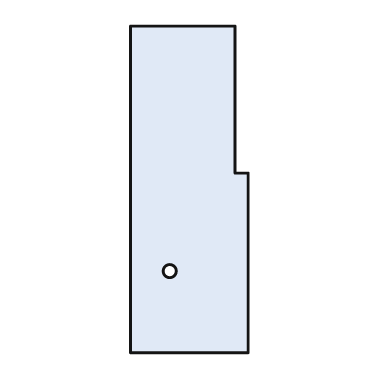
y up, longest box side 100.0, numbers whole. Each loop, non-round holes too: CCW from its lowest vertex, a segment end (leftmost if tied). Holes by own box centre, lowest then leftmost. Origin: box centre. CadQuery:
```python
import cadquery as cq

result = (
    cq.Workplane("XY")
    .moveTo(-18.0, -50.0)
    .lineTo(18.0, -50.0)
    .lineTo(18.0, 5.0)
    .lineTo(14.0, 5.0)
    .lineTo(14.0, 50.0)
    .lineTo(-18.0, 50.0)
    .close()
    .moveTo(-6.0, -25.0)
    .circle(2.0)
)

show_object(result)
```